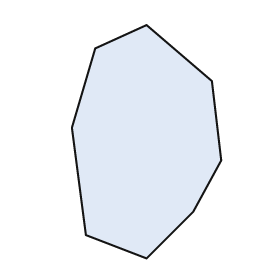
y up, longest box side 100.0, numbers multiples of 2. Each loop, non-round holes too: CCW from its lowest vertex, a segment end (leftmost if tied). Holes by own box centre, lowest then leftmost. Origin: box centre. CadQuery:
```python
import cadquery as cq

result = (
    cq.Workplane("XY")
    .moveTo(0.0, -50.0)
    .lineTo(20.0, -30.0)
    .lineTo(32.0, -8.0)
    .lineTo(28.0, 26.0)
    .lineTo(0.0, 50.0)
    .lineTo(-22.0, 40.0)
    .lineTo(-32.0, 6.0)
    .lineTo(-26.0, -40.0)
    .close()
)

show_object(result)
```